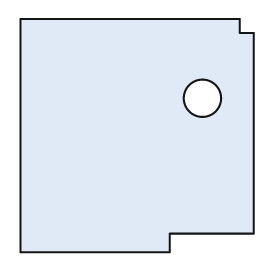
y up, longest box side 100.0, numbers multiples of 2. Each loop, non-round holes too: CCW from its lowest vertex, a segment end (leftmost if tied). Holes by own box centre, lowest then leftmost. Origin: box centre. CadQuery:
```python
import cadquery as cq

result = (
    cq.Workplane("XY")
    .moveTo(-50.0, -50.0)
    .lineTo(14.0, -50.0)
    .lineTo(14.0, -42.0)
    .lineTo(50.0, -42.0)
    .lineTo(50.0, 44.0)
    .lineTo(44.0, 44.0)
    .lineTo(44.0, 50.0)
    .lineTo(-50.0, 50.0)
    .close()
    .moveTo(28.0, 16.0)
    .circle(8.0)
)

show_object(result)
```